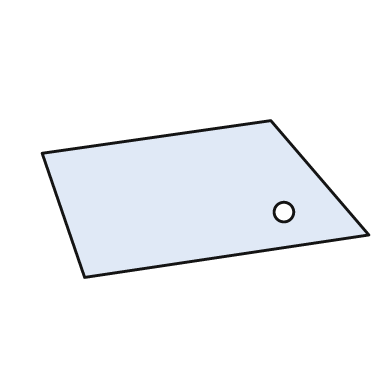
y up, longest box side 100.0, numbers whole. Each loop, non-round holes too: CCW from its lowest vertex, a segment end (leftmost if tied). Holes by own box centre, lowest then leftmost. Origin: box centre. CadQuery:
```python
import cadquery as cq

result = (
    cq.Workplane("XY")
    .moveTo(-37.0, -24.0)
    .lineTo(50.0, -11.0)
    .lineTo(20.0, 24.0)
    .lineTo(-50.0, 14.0)
    .close()
    .moveTo(24.0, -4.0)
    .circle(3.0)
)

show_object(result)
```